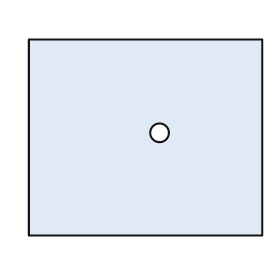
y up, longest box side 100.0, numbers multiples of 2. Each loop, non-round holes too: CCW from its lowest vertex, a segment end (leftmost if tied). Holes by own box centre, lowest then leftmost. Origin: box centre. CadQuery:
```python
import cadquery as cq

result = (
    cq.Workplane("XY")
    .moveTo(-50.0, -42.0)
    .lineTo(50.0, -42.0)
    .lineTo(50.0, 42.0)
    .lineTo(-50.0, 42.0)
    .close()
    .moveTo(6.0, 2.0)
    .circle(4.0)
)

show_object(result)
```